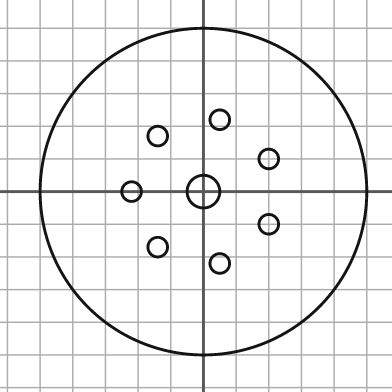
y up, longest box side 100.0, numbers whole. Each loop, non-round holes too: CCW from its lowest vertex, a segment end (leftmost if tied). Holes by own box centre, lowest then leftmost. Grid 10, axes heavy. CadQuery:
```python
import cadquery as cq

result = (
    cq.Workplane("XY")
    .moveTo(0.0, 0.0)
    .circle(50.0)
    .moveTo(5.0, -22.0)
    .circle(3.0)
    .moveTo(-14.0, -17.0)
    .circle(3.0)
    .moveTo(20.0, -10.0)
    .circle(3.0)
    .moveTo(-22.0, 0.0)
    .circle(3.0)
    .moveTo(0.0, 0.0)
    .circle(5.0)
    .moveTo(20.0, 10.0)
    .circle(3.0)
    .moveTo(-14.0, 17.0)
    .circle(3.0)
    .moveTo(5.0, 22.0)
    .circle(3.0)
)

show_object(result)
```